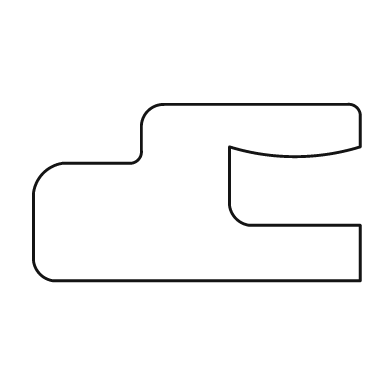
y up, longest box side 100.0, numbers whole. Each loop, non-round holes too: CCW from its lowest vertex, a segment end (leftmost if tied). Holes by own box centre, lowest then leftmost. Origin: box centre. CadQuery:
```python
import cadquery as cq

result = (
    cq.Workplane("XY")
    .moveTo(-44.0, -27.0)
    .lineTo(50.0, -27.0)
    .lineTo(50.0, -10.0)
    .lineTo(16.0, -10.0)
    .threePointArc((12.0, -8.0), (10.0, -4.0))
    .lineTo(10.0, 14.0)
    .threePointArc((30.0, 11.0), (50.0, 14.0))
    .lineTo(50.0, 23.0)
    .threePointArc((49.0, 26.0), (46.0, 27.0))
    .lineTo(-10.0, 27.0)
    .threePointArc((-15.0, 25.0), (-17.0, 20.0))
    .lineTo(-17.0, 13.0)
    .threePointArc((-18.0, 10.0), (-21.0, 9.0))
    .lineTo(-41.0, 9.0)
    .threePointArc((-47.0, 6.0), (-50.0, 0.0))
    .lineTo(-50.0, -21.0)
    .threePointArc((-48.0, -25.0), (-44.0, -27.0))
    .close()
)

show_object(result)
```